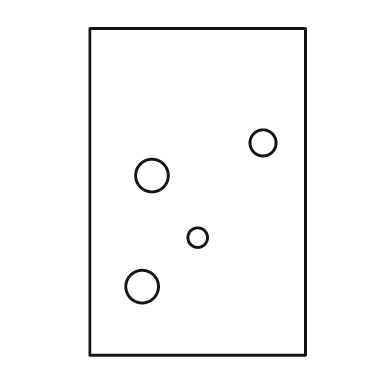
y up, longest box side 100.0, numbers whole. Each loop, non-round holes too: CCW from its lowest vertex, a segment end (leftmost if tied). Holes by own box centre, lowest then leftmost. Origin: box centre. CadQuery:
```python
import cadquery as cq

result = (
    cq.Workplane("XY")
    .moveTo(-33.0, -50.0)
    .lineTo(33.0, -50.0)
    .lineTo(33.0, 50.0)
    .lineTo(-33.0, 50.0)
    .close()
    .moveTo(-17.0, -29.0)
    .circle(5.0)
    .moveTo(0.0, -14.0)
    .circle(3.0)
    .moveTo(-14.0, 5.0)
    .circle(5.0)
    .moveTo(20.0, 15.0)
    .circle(4.0)
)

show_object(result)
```